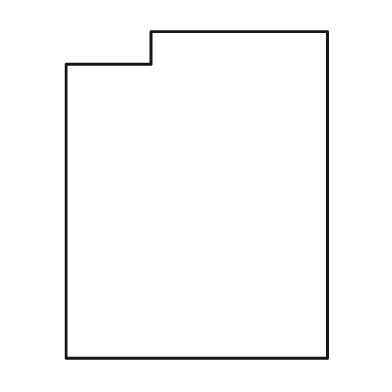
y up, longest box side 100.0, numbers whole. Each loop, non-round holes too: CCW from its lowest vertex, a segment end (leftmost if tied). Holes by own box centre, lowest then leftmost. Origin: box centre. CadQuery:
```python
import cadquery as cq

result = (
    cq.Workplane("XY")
    .moveTo(-40.0, -50.0)
    .lineTo(40.0, -50.0)
    .lineTo(40.0, 50.0)
    .lineTo(-14.0, 50.0)
    .lineTo(-14.0, 40.0)
    .lineTo(-40.0, 40.0)
    .close()
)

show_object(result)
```